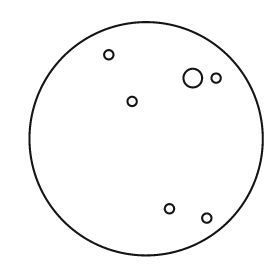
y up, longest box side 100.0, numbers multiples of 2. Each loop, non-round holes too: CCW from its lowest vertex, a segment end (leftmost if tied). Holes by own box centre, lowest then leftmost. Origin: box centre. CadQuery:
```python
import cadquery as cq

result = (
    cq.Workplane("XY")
    .moveTo(0.0, 0.0)
    .circle(50.0)
    .moveTo(26.0, -34.0)
    .circle(2.0)
    .moveTo(10.0, -30.0)
    .circle(2.0)
    .moveTo(-6.0, 16.0)
    .circle(2.0)
    .moveTo(20.0, 26.0)
    .circle(4.0)
    .moveTo(30.0, 26.0)
    .circle(2.0)
    .moveTo(-16.0, 36.0)
    .circle(2.0)
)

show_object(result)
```